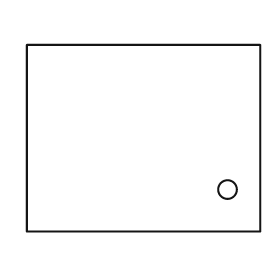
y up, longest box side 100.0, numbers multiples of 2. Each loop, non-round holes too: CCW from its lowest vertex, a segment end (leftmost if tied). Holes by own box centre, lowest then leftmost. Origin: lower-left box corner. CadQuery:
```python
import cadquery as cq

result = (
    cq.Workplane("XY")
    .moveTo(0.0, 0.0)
    .lineTo(100.0, 0.0)
    .lineTo(100.0, 80.0)
    .lineTo(0.0, 80.0)
    .close()
    .moveTo(86.0, 18.0)
    .circle(4.0)
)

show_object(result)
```